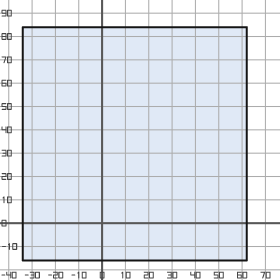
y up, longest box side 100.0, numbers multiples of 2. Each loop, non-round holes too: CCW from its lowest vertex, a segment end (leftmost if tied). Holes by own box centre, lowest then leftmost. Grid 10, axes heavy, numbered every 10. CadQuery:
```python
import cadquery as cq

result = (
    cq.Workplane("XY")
    .moveTo(-34.0, -16.0)
    .lineTo(62.0, -16.0)
    .lineTo(62.0, 84.0)
    .lineTo(-34.0, 84.0)
    .close()
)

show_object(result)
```